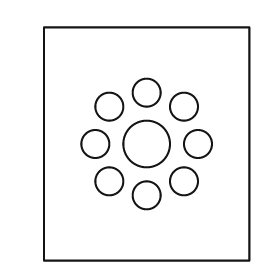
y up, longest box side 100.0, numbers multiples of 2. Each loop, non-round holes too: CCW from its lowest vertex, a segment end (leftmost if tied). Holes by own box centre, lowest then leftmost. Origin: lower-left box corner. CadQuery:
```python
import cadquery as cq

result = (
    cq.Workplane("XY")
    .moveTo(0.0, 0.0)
    .lineTo(88.0, 0.0)
    .lineTo(88.0, 100.0)
    .lineTo(0.0, 100.0)
    .close()
    .moveTo(44.0, 28.0)
    .circle(6.0)
    .moveTo(28.0, 34.0)
    .circle(6.0)
    .moveTo(60.0, 34.0)
    .circle(6.0)
    .moveTo(22.0, 50.0)
    .circle(6.0)
    .moveTo(44.0, 50.0)
    .circle(10.0)
    .moveTo(66.0, 50.0)
    .circle(6.0)
    .moveTo(28.0, 66.0)
    .circle(6.0)
    .moveTo(60.0, 66.0)
    .circle(6.0)
    .moveTo(44.0, 72.0)
    .circle(6.0)
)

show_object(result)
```